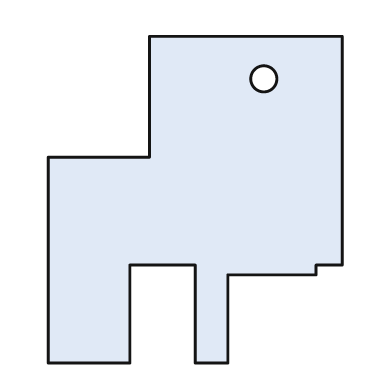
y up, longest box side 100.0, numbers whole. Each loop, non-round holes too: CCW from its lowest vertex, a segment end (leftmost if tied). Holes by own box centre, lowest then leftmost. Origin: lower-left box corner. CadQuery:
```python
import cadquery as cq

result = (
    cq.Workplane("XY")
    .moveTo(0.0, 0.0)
    .lineTo(25.0, 0.0)
    .lineTo(25.0, 30.0)
    .lineTo(45.0, 30.0)
    .lineTo(45.0, 0.0)
    .lineTo(55.0, 0.0)
    .lineTo(55.0, 27.0)
    .lineTo(82.0, 27.0)
    .lineTo(82.0, 30.0)
    .lineTo(90.0, 30.0)
    .lineTo(90.0, 100.0)
    .lineTo(31.0, 100.0)
    .lineTo(31.0, 63.0)
    .lineTo(0.0, 63.0)
    .close()
    .moveTo(66.0, 87.0)
    .circle(4.0)
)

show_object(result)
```